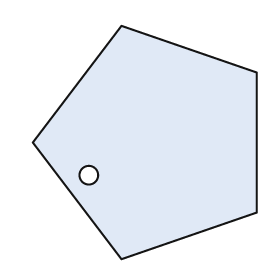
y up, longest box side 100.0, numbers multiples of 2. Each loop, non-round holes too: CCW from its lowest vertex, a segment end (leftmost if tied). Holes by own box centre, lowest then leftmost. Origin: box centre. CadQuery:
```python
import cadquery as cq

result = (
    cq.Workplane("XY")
    .moveTo(-10.0, -50.0)
    .lineTo(48.0, -30.0)
    .lineTo(48.0, 30.0)
    .lineTo(-10.0, 50.0)
    .lineTo(-48.0, 0.0)
    .close()
    .moveTo(-24.0, -14.0)
    .circle(4.0)
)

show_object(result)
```